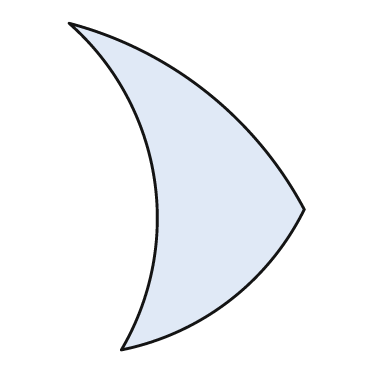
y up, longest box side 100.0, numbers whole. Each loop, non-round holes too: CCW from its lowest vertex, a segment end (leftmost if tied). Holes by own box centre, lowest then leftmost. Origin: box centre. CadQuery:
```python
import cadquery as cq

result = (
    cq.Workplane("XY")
    .moveTo(-20.0, -50.0)
    .threePointArc((13.0, -35.0), (36.0, -7.0))
    .threePointArc((6.0, 29.0), (-36.0, 50.0))
    .threePointArc((-10.0, 3.0), (-20.0, -50.0))
    .close()
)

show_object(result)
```